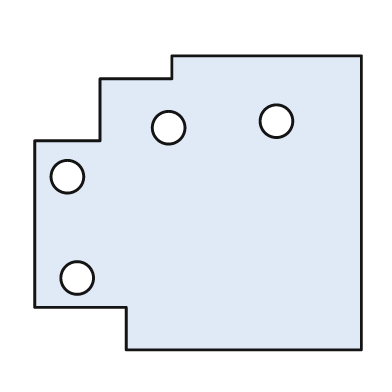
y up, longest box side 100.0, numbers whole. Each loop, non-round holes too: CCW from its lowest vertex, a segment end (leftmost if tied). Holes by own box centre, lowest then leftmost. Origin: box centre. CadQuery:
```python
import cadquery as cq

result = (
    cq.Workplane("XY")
    .moveTo(-22.0, -45.0)
    .lineTo(50.0, -45.0)
    .lineTo(50.0, 45.0)
    .lineTo(-8.0, 45.0)
    .lineTo(-8.0, 38.0)
    .lineTo(-30.0, 38.0)
    .lineTo(-30.0, 19.0)
    .lineTo(-50.0, 19.0)
    .lineTo(-50.0, -32.0)
    .lineTo(-22.0, -32.0)
    .close()
    .moveTo(-37.0, -23.0)
    .circle(5.0)
    .moveTo(-40.0, 8.0)
    .circle(5.0)
    .moveTo(-9.0, 23.0)
    .circle(5.0)
    .moveTo(24.0, 25.0)
    .circle(5.0)
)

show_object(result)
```